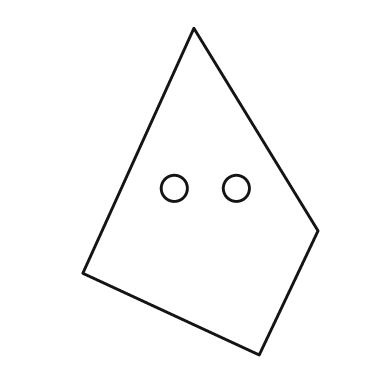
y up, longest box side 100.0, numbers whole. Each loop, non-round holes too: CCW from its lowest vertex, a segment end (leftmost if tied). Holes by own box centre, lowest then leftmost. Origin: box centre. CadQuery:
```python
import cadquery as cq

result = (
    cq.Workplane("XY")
    .moveTo(18.0, -50.0)
    .lineTo(36.0, -12.0)
    .lineTo(-2.0, 50.0)
    .lineTo(-36.0, -25.0)
    .close()
    .moveTo(-8.0, 1.0)
    .circle(4.0)
    .moveTo(11.0, 1.0)
    .circle(4.0)
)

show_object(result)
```